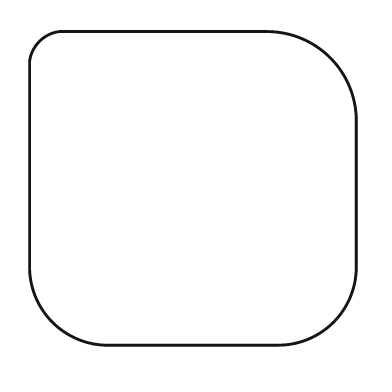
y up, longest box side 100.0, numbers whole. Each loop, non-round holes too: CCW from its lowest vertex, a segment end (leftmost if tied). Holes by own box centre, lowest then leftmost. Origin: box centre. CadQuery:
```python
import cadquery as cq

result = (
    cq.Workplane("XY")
    .moveTo(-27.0, -48.0)
    .lineTo(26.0, -48.0)
    .threePointArc((43.0, -41.0), (50.0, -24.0))
    .lineTo(50.0, 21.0)
    .threePointArc((42.0, 40.0), (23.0, 48.0))
    .lineTo(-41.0, 48.0)
    .threePointArc((-47.0, 45.0), (-50.0, 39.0))
    .lineTo(-50.0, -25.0)
    .threePointArc((-43.0, -41.0), (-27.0, -48.0))
    .close()
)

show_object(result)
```